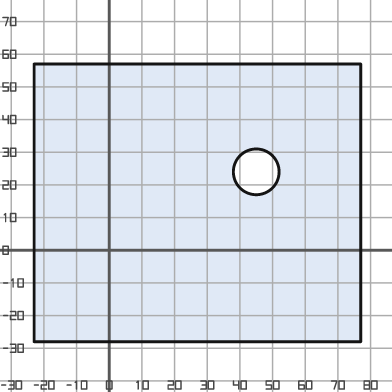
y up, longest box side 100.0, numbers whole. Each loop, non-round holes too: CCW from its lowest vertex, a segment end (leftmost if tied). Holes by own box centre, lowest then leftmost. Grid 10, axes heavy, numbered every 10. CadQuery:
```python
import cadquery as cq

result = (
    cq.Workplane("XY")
    .moveTo(-23.0, -28.0)
    .lineTo(77.0, -28.0)
    .lineTo(77.0, 57.0)
    .lineTo(-23.0, 57.0)
    .close()
    .moveTo(45.0, 24.0)
    .circle(7.0)
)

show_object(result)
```